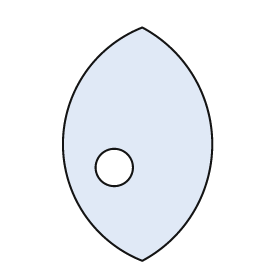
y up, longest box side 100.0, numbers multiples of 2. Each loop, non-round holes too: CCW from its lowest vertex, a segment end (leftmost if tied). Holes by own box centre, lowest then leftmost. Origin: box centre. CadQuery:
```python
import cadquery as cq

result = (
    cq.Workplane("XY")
    .moveTo(2.0, -50.0)
    .threePointArc((32.0, 0.0), (2.0, 50.0))
    .threePointArc((-32.0, 0.0), (2.0, -50.0))
    .close()
    .moveTo(-10.0, -10.0)
    .circle(8.0)
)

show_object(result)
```